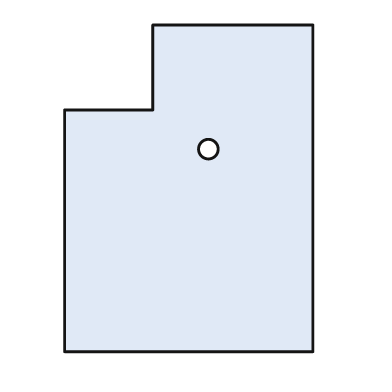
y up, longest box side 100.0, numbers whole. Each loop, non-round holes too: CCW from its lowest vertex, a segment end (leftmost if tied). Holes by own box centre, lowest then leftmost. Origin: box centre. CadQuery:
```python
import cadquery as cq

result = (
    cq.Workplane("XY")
    .moveTo(-38.0, -50.0)
    .lineTo(38.0, -50.0)
    .lineTo(38.0, 50.0)
    .lineTo(-11.0, 50.0)
    .lineTo(-11.0, 24.0)
    .lineTo(-38.0, 24.0)
    .close()
    .moveTo(6.0, 12.0)
    .circle(3.0)
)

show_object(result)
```